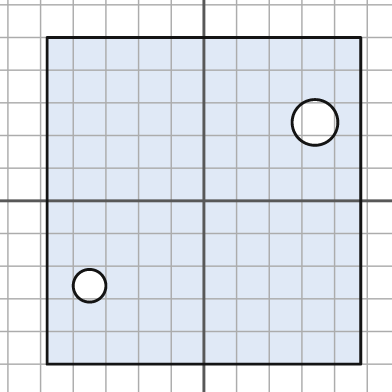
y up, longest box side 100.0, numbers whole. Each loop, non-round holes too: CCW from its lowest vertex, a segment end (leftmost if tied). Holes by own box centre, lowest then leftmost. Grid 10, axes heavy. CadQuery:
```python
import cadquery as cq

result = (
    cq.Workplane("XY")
    .moveTo(-48.0, -50.0)
    .lineTo(48.0, -50.0)
    .lineTo(48.0, 50.0)
    .lineTo(-48.0, 50.0)
    .close()
    .moveTo(-35.0, -26.0)
    .circle(5.0)
    .moveTo(34.0, 24.0)
    .circle(7.0)
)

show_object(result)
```